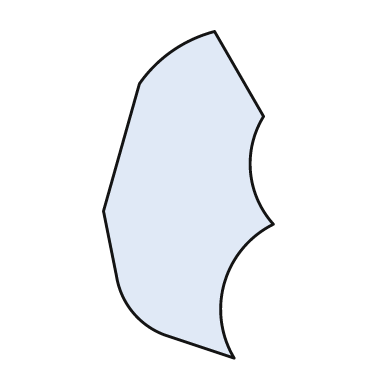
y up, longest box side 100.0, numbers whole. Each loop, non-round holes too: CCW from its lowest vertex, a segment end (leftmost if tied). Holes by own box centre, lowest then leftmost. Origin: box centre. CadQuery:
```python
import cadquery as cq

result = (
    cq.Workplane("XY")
    .moveTo(14.0, -50.0)
    .threePointArc((11.0, -27.0), (26.0, -9.0))
    .threePointArc((19.0, 7.0), (23.0, 24.0))
    .lineTo(8.0, 50.0)
    .threePointArc((-5.0, 44.0), (-15.0, 34.0))
    .lineTo(-26.0, -5.0)
    .lineTo(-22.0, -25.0)
    .threePointArc((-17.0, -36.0), (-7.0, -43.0))
    .close()
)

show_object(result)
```